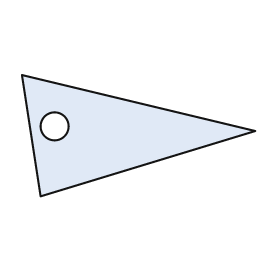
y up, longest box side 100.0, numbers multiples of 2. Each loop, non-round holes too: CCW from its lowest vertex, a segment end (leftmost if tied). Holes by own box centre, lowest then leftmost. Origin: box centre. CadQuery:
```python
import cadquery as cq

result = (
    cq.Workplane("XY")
    .moveTo(-42.0, -26.0)
    .lineTo(50.0, 2.0)
    .lineTo(-50.0, 26.0)
    .close()
    .moveTo(-36.0, 4.0)
    .circle(6.0)
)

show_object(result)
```